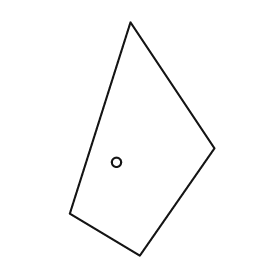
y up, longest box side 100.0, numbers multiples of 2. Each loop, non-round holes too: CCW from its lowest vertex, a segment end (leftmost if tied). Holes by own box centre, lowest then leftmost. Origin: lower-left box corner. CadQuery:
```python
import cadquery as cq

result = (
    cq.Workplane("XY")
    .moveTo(30.0, 0.0)
    .lineTo(62.0, 46.0)
    .lineTo(26.0, 100.0)
    .lineTo(0.0, 18.0)
    .close()
    .moveTo(20.0, 40.0)
    .circle(2.0)
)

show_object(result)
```